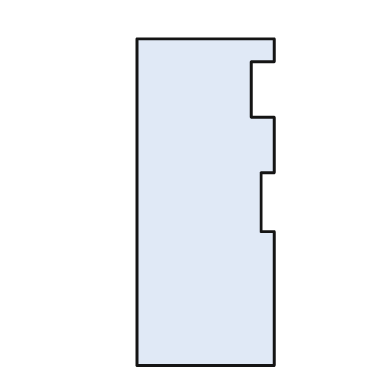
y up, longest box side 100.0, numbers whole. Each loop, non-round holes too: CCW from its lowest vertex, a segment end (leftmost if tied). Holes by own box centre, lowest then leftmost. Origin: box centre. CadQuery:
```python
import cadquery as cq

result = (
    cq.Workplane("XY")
    .moveTo(-21.0, -50.0)
    .lineTo(21.0, -50.0)
    .lineTo(21.0, -9.0)
    .lineTo(17.0, -9.0)
    .lineTo(17.0, 9.0)
    .lineTo(21.0, 9.0)
    .lineTo(21.0, 26.0)
    .lineTo(14.0, 26.0)
    .lineTo(14.0, 43.0)
    .lineTo(21.0, 43.0)
    .lineTo(21.0, 50.0)
    .lineTo(-21.0, 50.0)
    .close()
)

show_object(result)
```